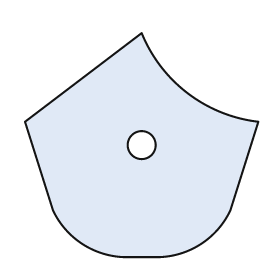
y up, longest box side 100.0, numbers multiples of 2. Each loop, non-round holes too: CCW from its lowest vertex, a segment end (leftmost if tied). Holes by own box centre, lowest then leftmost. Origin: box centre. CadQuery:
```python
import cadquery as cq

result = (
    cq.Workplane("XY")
    .moveTo(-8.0, -48.0)
    .lineTo(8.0, -48.0)
    .threePointArc((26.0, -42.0), (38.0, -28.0))
    .lineTo(50.0, 10.0)
    .threePointArc((20.0, 22.0), (0.0, 48.0))
    .lineTo(-50.0, 10.0)
    .lineTo(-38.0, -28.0)
    .threePointArc((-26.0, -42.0), (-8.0, -48.0))
    .close()
    .moveTo(0.0, 0.0)
    .circle(6.0)
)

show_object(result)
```